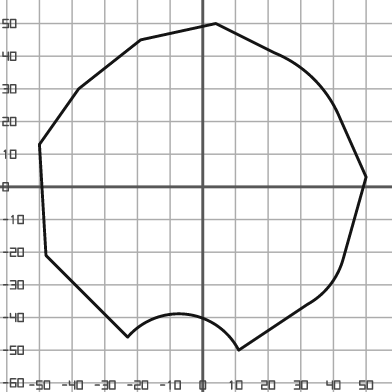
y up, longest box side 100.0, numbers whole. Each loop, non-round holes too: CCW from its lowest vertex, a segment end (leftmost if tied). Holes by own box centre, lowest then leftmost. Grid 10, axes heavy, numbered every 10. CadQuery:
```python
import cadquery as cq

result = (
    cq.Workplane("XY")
    .moveTo(11.0, -50.0)
    .lineTo(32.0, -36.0)
    .threePointArc((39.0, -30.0), (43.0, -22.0))
    .lineTo(50.0, 3.0)
    .lineTo(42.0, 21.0)
    .threePointArc((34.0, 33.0), (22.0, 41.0))
    .lineTo(4.0, 50.0)
    .lineTo(-19.0, 45.0)
    .lineTo(-38.0, 30.0)
    .lineTo(-50.0, 13.0)
    .lineTo(-48.0, -21.0)
    .lineTo(-23.0, -46.0)
    .threePointArc((-5.0, -39.0), (11.0, -50.0))
    .close()
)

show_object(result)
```